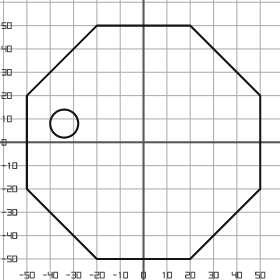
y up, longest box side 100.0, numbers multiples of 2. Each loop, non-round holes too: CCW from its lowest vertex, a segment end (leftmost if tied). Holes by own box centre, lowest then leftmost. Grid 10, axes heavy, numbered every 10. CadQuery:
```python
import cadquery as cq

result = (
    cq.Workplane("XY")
    .moveTo(-20.0, -50.0)
    .lineTo(20.0, -50.0)
    .lineTo(50.0, -20.0)
    .lineTo(50.0, 20.0)
    .lineTo(20.0, 50.0)
    .lineTo(-20.0, 50.0)
    .lineTo(-50.0, 20.0)
    .lineTo(-50.0, -20.0)
    .close()
    .moveTo(-34.0, 8.0)
    .circle(6.0)
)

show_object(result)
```